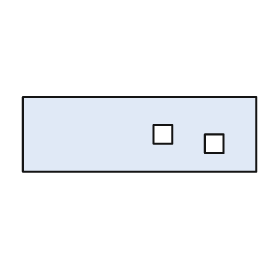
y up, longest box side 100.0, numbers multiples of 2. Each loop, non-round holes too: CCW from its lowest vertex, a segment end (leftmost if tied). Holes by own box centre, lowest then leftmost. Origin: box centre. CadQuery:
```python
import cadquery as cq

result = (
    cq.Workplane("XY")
    .moveTo(-50.0, -16.0)
    .lineTo(50.0, -16.0)
    .lineTo(50.0, 16.0)
    .lineTo(-50.0, 16.0)
    .close()
    .moveTo(28.0, -8.0)
    .lineTo(36.0, -8.0)
    .lineTo(36.0, 0.0)
    .lineTo(28.0, 0.0)
    .close()
    .moveTo(6.0, -4.0)
    .lineTo(14.0, -4.0)
    .lineTo(14.0, 4.0)
    .lineTo(6.0, 4.0)
    .close()
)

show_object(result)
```